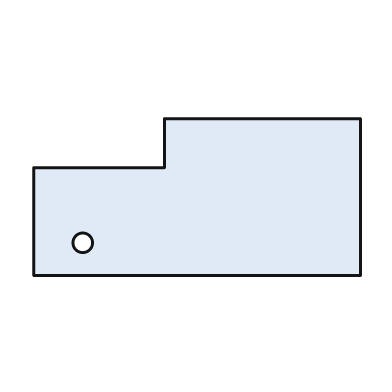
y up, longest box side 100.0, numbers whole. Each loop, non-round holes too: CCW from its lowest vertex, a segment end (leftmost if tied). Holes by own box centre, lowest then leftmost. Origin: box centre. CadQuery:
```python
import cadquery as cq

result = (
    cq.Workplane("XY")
    .moveTo(-50.0, -24.0)
    .lineTo(50.0, -24.0)
    .lineTo(50.0, 24.0)
    .lineTo(-10.0, 24.0)
    .lineTo(-10.0, 9.0)
    .lineTo(-50.0, 9.0)
    .close()
    .moveTo(-35.0, -14.0)
    .circle(3.0)
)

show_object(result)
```